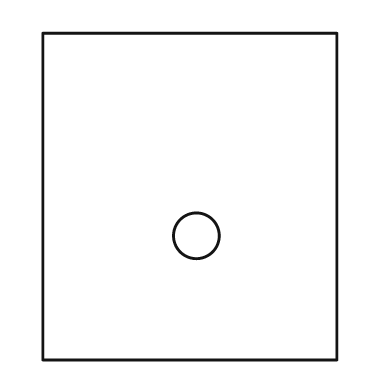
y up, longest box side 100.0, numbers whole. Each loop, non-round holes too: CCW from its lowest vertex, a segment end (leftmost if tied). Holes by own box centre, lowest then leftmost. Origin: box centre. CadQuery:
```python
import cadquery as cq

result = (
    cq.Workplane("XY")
    .moveTo(-45.0, -50.0)
    .lineTo(45.0, -50.0)
    .lineTo(45.0, 50.0)
    .lineTo(-45.0, 50.0)
    .close()
    .moveTo(2.0, -12.0)
    .circle(7.0)
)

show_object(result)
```